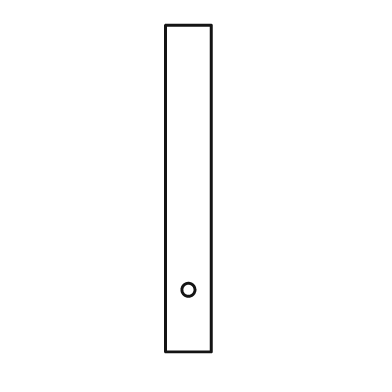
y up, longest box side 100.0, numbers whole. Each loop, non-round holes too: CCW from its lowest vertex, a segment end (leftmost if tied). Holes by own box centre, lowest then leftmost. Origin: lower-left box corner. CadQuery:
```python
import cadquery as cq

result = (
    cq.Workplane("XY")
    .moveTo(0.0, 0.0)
    .lineTo(14.0, 0.0)
    .lineTo(14.0, 100.0)
    .lineTo(0.0, 100.0)
    .close()
    .moveTo(7.0, 19.0)
    .circle(2.0)
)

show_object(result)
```